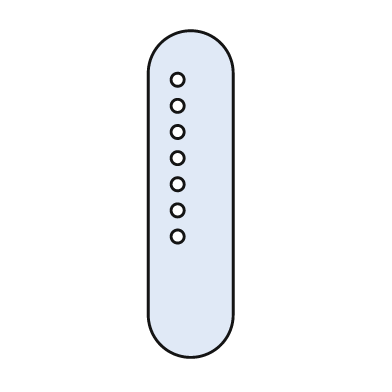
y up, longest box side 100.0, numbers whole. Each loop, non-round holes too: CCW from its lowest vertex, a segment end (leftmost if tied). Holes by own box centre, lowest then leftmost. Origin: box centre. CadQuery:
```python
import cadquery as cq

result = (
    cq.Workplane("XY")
    .moveTo(-13.0, -37.0)
    .threePointArc((0.0, -50.0), (13.0, -37.0))
    .lineTo(13.0, 37.0)
    .threePointArc((0.0, 50.0), (-13.0, 37.0))
    .close()
    .moveTo(-4.0, -13.0)
    .circle(2.0)
    .moveTo(-4.0, -5.0)
    .circle(2.0)
    .moveTo(-4.0, 3.0)
    .circle(2.0)
    .moveTo(-4.0, 11.0)
    .circle(2.0)
    .moveTo(-4.0, 19.0)
    .circle(2.0)
    .moveTo(-4.0, 27.0)
    .circle(2.0)
    .moveTo(-4.0, 35.0)
    .circle(2.0)
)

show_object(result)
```